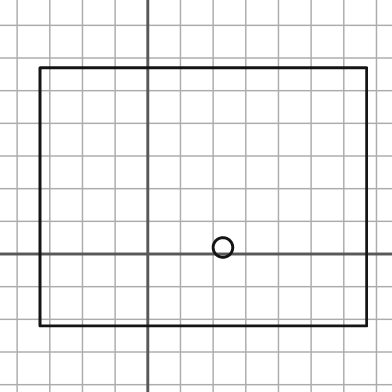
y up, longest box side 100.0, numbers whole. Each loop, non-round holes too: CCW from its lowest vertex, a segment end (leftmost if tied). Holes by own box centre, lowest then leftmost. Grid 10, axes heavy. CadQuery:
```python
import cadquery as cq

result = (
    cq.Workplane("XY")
    .moveTo(-33.0, -22.0)
    .lineTo(67.0, -22.0)
    .lineTo(67.0, 57.0)
    .lineTo(-33.0, 57.0)
    .close()
    .moveTo(23.0, 2.0)
    .circle(3.0)
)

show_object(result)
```